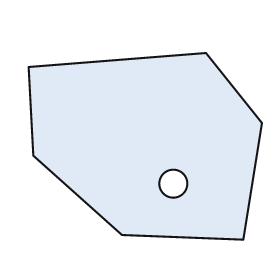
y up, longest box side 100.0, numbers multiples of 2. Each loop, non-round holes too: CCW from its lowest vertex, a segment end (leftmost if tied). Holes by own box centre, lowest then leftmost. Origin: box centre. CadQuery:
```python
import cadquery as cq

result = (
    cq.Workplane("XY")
    .moveTo(42.0, -40.0)
    .lineTo(50.0, 10.0)
    .lineTo(26.0, 40.0)
    .lineTo(-50.0, 34.0)
    .lineTo(-48.0, -4.0)
    .lineTo(-10.0, -38.0)
    .close()
    .moveTo(12.0, -16.0)
    .circle(6.0)
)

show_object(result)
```